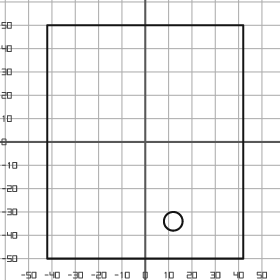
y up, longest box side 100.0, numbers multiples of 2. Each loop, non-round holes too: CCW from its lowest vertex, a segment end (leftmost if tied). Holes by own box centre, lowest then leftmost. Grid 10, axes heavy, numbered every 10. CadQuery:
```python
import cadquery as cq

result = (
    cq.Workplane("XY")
    .moveTo(-42.0, -50.0)
    .lineTo(42.0, -50.0)
    .lineTo(42.0, 50.0)
    .lineTo(-42.0, 50.0)
    .close()
    .moveTo(12.0, -34.0)
    .circle(4.0)
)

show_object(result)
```